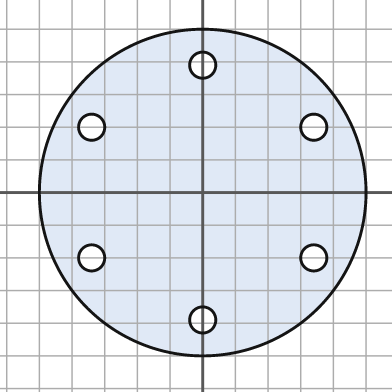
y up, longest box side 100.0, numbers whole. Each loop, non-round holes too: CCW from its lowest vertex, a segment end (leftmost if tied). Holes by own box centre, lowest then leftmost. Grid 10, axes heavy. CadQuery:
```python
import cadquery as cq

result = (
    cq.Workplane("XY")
    .moveTo(0.0, 0.0)
    .circle(50.0)
    .moveTo(0.0, -39.0)
    .circle(4.0)
    .moveTo(-34.0, -20.0)
    .circle(4.0)
    .moveTo(34.0, -20.0)
    .circle(4.0)
    .moveTo(-34.0, 20.0)
    .circle(4.0)
    .moveTo(34.0, 20.0)
    .circle(4.0)
    .moveTo(0.0, 39.0)
    .circle(4.0)
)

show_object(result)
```